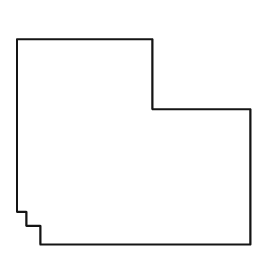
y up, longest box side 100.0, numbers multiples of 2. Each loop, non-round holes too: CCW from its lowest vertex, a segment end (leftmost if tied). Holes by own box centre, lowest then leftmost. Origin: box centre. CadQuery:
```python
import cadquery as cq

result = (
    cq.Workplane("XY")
    .moveTo(-40.0, -44.0)
    .lineTo(50.0, -44.0)
    .lineTo(50.0, 14.0)
    .lineTo(8.0, 14.0)
    .lineTo(8.0, 44.0)
    .lineTo(-50.0, 44.0)
    .lineTo(-50.0, -30.0)
    .lineTo(-46.0, -30.0)
    .lineTo(-46.0, -36.0)
    .lineTo(-40.0, -36.0)
    .close()
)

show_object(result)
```